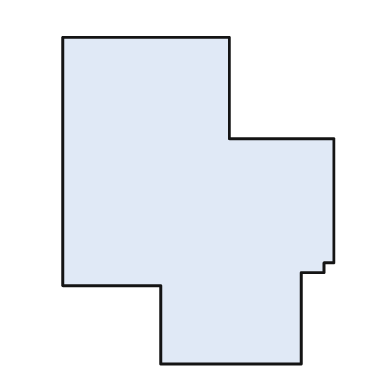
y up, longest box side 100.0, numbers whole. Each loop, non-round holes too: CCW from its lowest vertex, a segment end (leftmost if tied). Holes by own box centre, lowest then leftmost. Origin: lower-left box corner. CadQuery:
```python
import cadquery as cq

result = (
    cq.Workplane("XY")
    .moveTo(30.0, 0.0)
    .lineTo(73.0, 0.0)
    .lineTo(73.0, 28.0)
    .lineTo(80.0, 28.0)
    .lineTo(80.0, 31.0)
    .lineTo(83.0, 31.0)
    .lineTo(83.0, 69.0)
    .lineTo(51.0, 69.0)
    .lineTo(51.0, 100.0)
    .lineTo(0.0, 100.0)
    .lineTo(0.0, 24.0)
    .lineTo(30.0, 24.0)
    .close()
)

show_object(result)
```